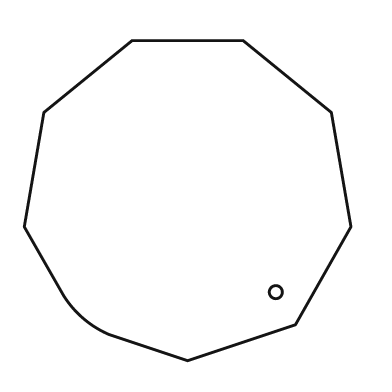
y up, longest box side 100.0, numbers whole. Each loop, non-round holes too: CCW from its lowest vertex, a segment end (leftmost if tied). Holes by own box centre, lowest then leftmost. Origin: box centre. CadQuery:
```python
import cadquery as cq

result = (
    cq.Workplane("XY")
    .moveTo(0.0, -49.0)
    .lineTo(33.0, -38.0)
    .lineTo(50.0, -8.0)
    .lineTo(44.0, 27.0)
    .lineTo(17.0, 49.0)
    .lineTo(-17.0, 49.0)
    .lineTo(-44.0, 27.0)
    .lineTo(-50.0, -8.0)
    .lineTo(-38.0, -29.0)
    .threePointArc((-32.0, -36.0), (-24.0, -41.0))
    .close()
    .moveTo(27.0, -28.0)
    .circle(2.0)
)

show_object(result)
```